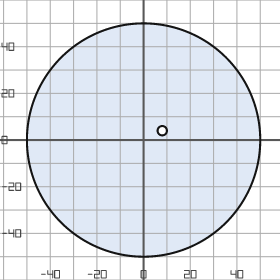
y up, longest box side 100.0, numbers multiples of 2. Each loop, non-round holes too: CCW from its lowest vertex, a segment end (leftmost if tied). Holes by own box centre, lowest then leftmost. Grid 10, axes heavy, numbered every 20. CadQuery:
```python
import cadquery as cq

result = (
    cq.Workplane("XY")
    .moveTo(0.0, 0.0)
    .circle(50.0)
    .moveTo(8.0, 4.0)
    .circle(2.0)
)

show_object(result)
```